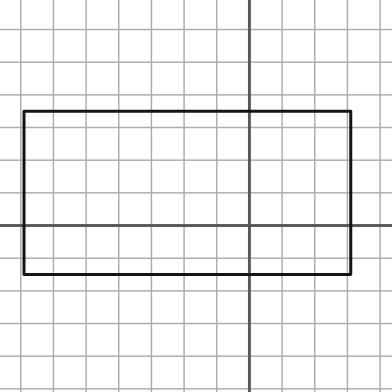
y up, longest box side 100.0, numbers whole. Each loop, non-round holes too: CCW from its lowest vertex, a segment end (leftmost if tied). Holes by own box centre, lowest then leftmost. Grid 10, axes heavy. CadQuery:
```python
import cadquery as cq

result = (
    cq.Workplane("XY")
    .moveTo(-69.0, -15.0)
    .lineTo(31.0, -15.0)
    .lineTo(31.0, 35.0)
    .lineTo(-69.0, 35.0)
    .close()
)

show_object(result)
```